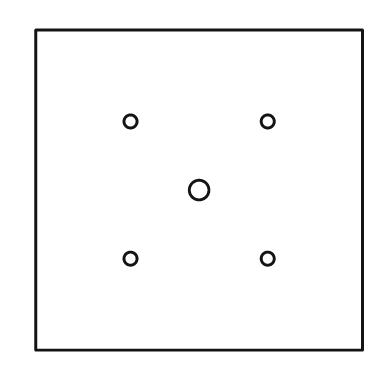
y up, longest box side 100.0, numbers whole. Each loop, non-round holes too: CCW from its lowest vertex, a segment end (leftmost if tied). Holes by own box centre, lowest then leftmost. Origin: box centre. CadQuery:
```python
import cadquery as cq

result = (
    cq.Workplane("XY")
    .moveTo(-50.0, -49.0)
    .lineTo(50.0, -49.0)
    .lineTo(50.0, 49.0)
    .lineTo(-50.0, 49.0)
    .close()
    .moveTo(-21.0, -21.0)
    .circle(2.0)
    .moveTo(21.0, -21.0)
    .circle(2.0)
    .moveTo(0.0, 0.0)
    .circle(3.0)
    .moveTo(-21.0, 21.0)
    .circle(2.0)
    .moveTo(21.0, 21.0)
    .circle(2.0)
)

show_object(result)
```